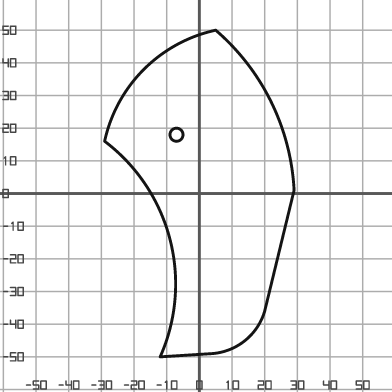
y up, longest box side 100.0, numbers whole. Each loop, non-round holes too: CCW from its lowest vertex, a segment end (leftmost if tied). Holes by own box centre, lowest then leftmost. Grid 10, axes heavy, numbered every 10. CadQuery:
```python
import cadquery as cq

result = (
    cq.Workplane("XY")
    .moveTo(-12.0, -50.0)
    .lineTo(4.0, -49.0)
    .threePointArc((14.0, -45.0), (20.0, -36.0))
    .lineTo(29.0, 1.0)
    .threePointArc((22.0, 28.0), (5.0, 50.0))
    .threePointArc((-17.0, 38.0), (-29.0, 16.0))
    .threePointArc((-9.0, -14.0), (-12.0, -50.0))
    .close()
    .moveTo(-7.0, 18.0)
    .circle(2.0)
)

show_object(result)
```